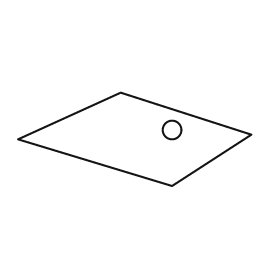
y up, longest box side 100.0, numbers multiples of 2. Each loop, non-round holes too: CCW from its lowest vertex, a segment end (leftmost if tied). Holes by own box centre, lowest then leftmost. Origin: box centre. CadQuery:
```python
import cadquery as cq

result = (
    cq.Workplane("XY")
    .moveTo(16.0, -20.0)
    .lineTo(50.0, 2.0)
    .lineTo(-6.0, 20.0)
    .lineTo(-50.0, 0.0)
    .close()
    .moveTo(16.0, 4.0)
    .circle(4.0)
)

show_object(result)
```